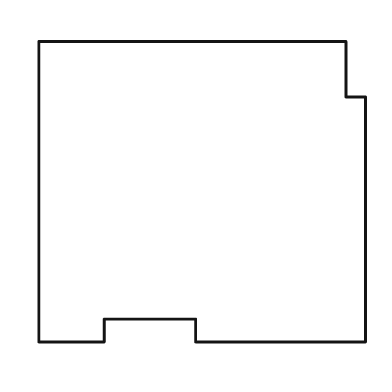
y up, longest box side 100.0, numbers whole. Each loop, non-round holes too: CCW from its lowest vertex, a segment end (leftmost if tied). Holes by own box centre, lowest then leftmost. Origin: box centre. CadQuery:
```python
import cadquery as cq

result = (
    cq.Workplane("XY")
    .moveTo(-50.0, -46.0)
    .lineTo(-30.0, -46.0)
    .lineTo(-30.0, -39.0)
    .lineTo(-2.0, -39.0)
    .lineTo(-2.0, -46.0)
    .lineTo(50.0, -46.0)
    .lineTo(50.0, 29.0)
    .lineTo(44.0, 29.0)
    .lineTo(44.0, 46.0)
    .lineTo(-50.0, 46.0)
    .close()
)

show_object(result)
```